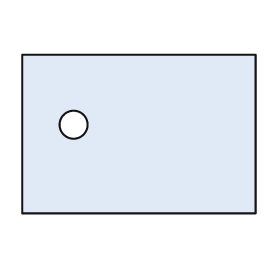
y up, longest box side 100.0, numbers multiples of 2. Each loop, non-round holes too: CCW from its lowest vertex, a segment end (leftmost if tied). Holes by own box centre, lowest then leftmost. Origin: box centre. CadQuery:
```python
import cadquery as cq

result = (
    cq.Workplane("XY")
    .moveTo(-50.0, -34.0)
    .lineTo(50.0, -34.0)
    .lineTo(50.0, 34.0)
    .lineTo(-50.0, 34.0)
    .close()
    .moveTo(-28.0, 4.0)
    .circle(6.0)
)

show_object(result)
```